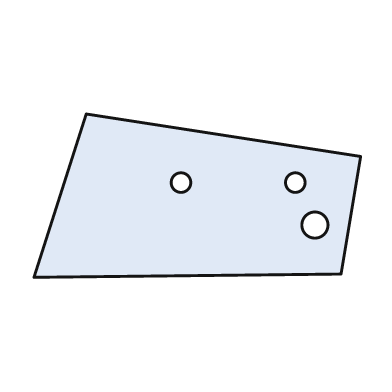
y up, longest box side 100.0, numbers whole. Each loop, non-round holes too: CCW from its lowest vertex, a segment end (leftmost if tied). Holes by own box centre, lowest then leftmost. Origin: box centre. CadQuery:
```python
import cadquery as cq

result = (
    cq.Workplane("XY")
    .moveTo(-50.0, -25.0)
    .lineTo(44.0, -24.0)
    .lineTo(50.0, 12.0)
    .lineTo(-34.0, 25.0)
    .close()
    .moveTo(36.0, -9.0)
    .circle(4.0)
    .moveTo(-5.0, 4.0)
    .circle(3.0)
    .moveTo(30.0, 4.0)
    .circle(3.0)
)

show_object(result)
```